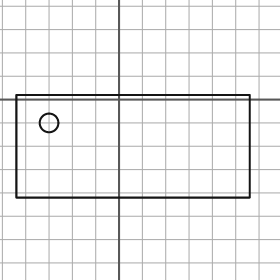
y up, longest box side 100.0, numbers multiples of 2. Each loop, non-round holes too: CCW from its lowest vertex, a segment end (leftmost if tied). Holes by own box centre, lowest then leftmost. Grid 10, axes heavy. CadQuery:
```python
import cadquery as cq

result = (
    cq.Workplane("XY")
    .moveTo(-44.0, -42.0)
    .lineTo(56.0, -42.0)
    .lineTo(56.0, 2.0)
    .lineTo(-44.0, 2.0)
    .close()
    .moveTo(-30.0, -10.0)
    .circle(4.0)
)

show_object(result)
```